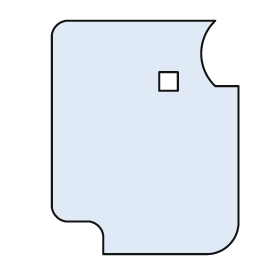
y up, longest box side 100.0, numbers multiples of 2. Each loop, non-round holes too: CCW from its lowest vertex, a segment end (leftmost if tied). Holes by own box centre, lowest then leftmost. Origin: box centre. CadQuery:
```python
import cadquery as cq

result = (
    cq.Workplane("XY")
    .moveTo(-18.0, -50.0)
    .lineTo(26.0, -50.0)
    .threePointArc((36.0, -46.0), (40.0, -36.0))
    .lineTo(40.0, 22.0)
    .lineTo(30.0, 22.0)
    .threePointArc((24.0, 36.0), (30.0, 50.0))
    .lineTo(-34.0, 50.0)
    .threePointArc((-38.0, 48.0), (-40.0, 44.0))
    .lineTo(-40.0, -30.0)
    .threePointArc((-38.0, -34.0), (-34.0, -36.0))
    .lineTo(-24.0, -36.0)
    .threePointArc((-20.0, -38.0), (-18.0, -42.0))
    .close()
    .moveTo(6.0, 20.0)
    .lineTo(14.0, 20.0)
    .lineTo(14.0, 28.0)
    .lineTo(6.0, 28.0)
    .close()
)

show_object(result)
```